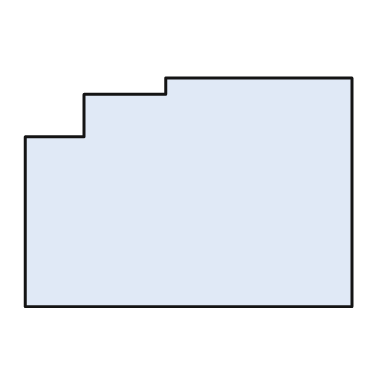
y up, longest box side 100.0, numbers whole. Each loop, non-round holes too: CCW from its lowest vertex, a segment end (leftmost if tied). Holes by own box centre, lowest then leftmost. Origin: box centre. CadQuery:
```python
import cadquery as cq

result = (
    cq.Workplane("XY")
    .moveTo(-50.0, -35.0)
    .lineTo(50.0, -35.0)
    .lineTo(50.0, 35.0)
    .lineTo(-7.0, 35.0)
    .lineTo(-7.0, 30.0)
    .lineTo(-32.0, 30.0)
    .lineTo(-32.0, 17.0)
    .lineTo(-50.0, 17.0)
    .close()
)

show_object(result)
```